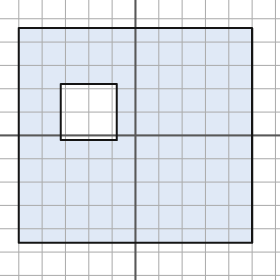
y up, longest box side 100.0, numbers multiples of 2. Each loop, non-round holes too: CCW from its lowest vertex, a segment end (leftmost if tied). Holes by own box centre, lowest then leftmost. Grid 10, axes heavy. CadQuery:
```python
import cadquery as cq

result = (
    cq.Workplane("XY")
    .moveTo(-50.0, -46.0)
    .lineTo(50.0, -46.0)
    .lineTo(50.0, 46.0)
    .lineTo(-50.0, 46.0)
    .close()
    .moveTo(-32.0, -2.0)
    .lineTo(-8.0, -2.0)
    .lineTo(-8.0, 22.0)
    .lineTo(-32.0, 22.0)
    .close()
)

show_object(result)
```